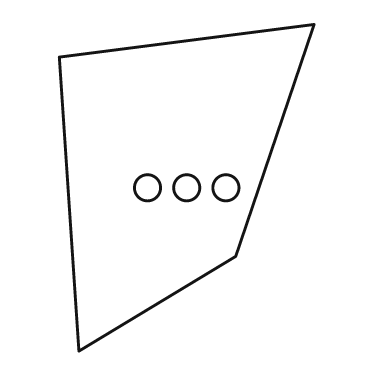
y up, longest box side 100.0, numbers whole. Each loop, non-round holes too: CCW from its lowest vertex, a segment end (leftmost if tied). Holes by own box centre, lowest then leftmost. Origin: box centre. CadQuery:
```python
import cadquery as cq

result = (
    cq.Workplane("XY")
    .moveTo(-33.0, -50.0)
    .lineTo(15.0, -21.0)
    .lineTo(39.0, 50.0)
    .lineTo(-39.0, 40.0)
    .close()
    .moveTo(-12.0, 0.0)
    .circle(4.0)
    .moveTo(0.0, 0.0)
    .circle(4.0)
    .moveTo(12.0, 0.0)
    .circle(4.0)
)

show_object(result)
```